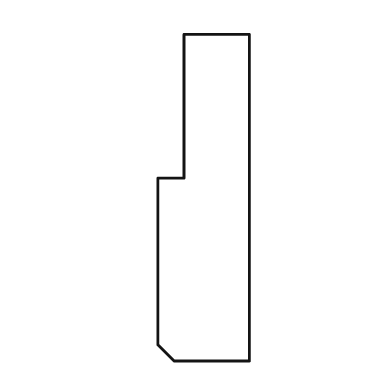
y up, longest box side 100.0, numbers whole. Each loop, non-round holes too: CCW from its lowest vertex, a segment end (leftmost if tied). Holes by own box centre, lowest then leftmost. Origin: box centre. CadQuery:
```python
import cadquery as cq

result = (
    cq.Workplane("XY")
    .moveTo(-9.0, -50.0)
    .lineTo(14.0, -50.0)
    .lineTo(14.0, 50.0)
    .lineTo(-6.0, 50.0)
    .lineTo(-6.0, 6.0)
    .lineTo(-14.0, 6.0)
    .lineTo(-14.0, -45.0)
    .close()
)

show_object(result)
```